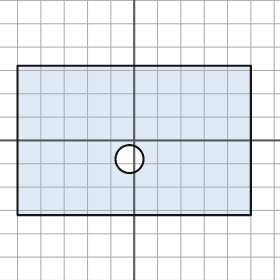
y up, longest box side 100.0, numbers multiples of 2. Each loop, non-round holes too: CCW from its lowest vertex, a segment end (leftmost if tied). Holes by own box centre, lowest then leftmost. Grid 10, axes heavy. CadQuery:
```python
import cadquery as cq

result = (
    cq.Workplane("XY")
    .moveTo(-50.0, -32.0)
    .lineTo(50.0, -32.0)
    .lineTo(50.0, 32.0)
    .lineTo(-50.0, 32.0)
    .close()
    .moveTo(-2.0, -8.0)
    .circle(6.0)
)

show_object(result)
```